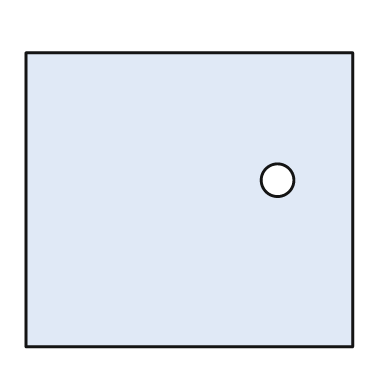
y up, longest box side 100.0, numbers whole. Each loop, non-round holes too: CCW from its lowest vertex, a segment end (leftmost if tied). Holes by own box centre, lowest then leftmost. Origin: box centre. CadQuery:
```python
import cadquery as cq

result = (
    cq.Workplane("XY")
    .moveTo(-50.0, -45.0)
    .lineTo(50.0, -45.0)
    .lineTo(50.0, 45.0)
    .lineTo(-50.0, 45.0)
    .close()
    .moveTo(27.0, 6.0)
    .circle(5.0)
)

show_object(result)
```